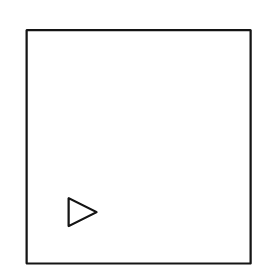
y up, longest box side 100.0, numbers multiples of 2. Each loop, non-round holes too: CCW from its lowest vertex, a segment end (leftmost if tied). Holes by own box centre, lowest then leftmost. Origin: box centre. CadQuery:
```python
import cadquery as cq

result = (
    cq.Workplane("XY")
    .moveTo(-48.0, -50.0)
    .lineTo(48.0, -50.0)
    .lineTo(48.0, 50.0)
    .lineTo(-48.0, 50.0)
    .close()
    .moveTo(-30.0, -34.0)
    .lineTo(-18.0, -28.0)
    .lineTo(-30.0, -22.0)
    .close()
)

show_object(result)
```